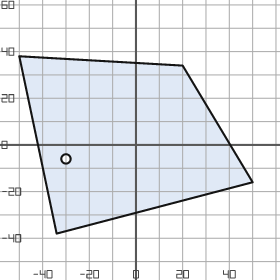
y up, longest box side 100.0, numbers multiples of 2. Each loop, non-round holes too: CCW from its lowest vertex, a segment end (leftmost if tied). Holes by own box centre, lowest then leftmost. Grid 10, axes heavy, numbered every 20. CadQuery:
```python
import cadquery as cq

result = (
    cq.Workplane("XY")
    .moveTo(-34.0, -38.0)
    .lineTo(50.0, -16.0)
    .lineTo(20.0, 34.0)
    .lineTo(-50.0, 38.0)
    .close()
    .moveTo(-30.0, -6.0)
    .circle(2.0)
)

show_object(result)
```